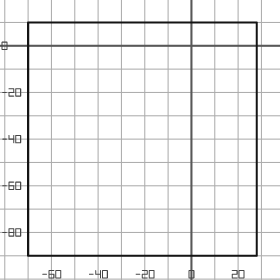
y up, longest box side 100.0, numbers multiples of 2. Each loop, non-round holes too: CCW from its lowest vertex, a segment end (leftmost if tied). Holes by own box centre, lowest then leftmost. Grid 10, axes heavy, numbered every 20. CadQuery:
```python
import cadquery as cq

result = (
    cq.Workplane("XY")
    .moveTo(-70.0, -90.0)
    .lineTo(28.0, -90.0)
    .lineTo(28.0, 10.0)
    .lineTo(-70.0, 10.0)
    .close()
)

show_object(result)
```